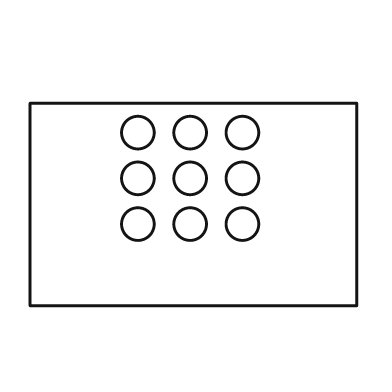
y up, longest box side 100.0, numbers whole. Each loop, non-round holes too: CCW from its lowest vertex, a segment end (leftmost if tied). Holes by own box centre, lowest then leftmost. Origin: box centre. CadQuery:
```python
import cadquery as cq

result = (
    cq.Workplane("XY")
    .moveTo(-50.0, -31.0)
    .lineTo(50.0, -31.0)
    .lineTo(50.0, 31.0)
    .lineTo(-50.0, 31.0)
    .close()
    .moveTo(-17.0, -6.0)
    .circle(5.0)
    .moveTo(-1.0, -6.0)
    .circle(5.0)
    .moveTo(15.0, -6.0)
    .circle(5.0)
    .moveTo(-17.0, 8.0)
    .circle(5.0)
    .moveTo(-1.0, 8.0)
    .circle(5.0)
    .moveTo(15.0, 8.0)
    .circle(5.0)
    .moveTo(-17.0, 22.0)
    .circle(5.0)
    .moveTo(-1.0, 22.0)
    .circle(5.0)
    .moveTo(15.0, 22.0)
    .circle(5.0)
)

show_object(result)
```